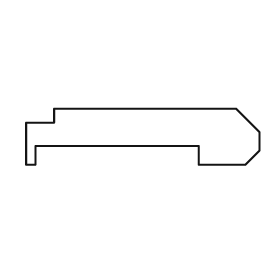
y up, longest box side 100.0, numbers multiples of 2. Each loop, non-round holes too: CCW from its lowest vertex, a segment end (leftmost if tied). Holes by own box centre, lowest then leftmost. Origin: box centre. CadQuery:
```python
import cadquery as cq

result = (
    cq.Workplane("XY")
    .moveTo(-50.0, -12.0)
    .lineTo(-46.0, -12.0)
    .lineTo(-46.0, -4.0)
    .lineTo(24.0, -4.0)
    .lineTo(24.0, -12.0)
    .lineTo(44.0, -12.0)
    .lineTo(50.0, -6.0)
    .lineTo(50.0, 2.0)
    .lineTo(40.0, 12.0)
    .lineTo(-38.0, 12.0)
    .lineTo(-38.0, 6.0)
    .lineTo(-50.0, 6.0)
    .close()
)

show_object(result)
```